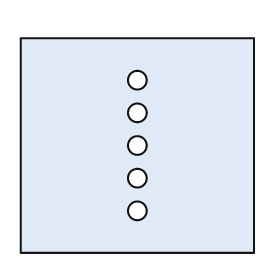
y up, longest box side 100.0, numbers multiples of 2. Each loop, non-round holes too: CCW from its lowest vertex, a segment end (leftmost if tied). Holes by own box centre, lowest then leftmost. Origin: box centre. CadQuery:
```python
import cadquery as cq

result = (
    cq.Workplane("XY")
    .moveTo(-50.0, -46.0)
    .lineTo(50.0, -46.0)
    .lineTo(50.0, 46.0)
    .lineTo(-50.0, 46.0)
    .close()
    .moveTo(0.0, -28.0)
    .circle(4.0)
    .moveTo(0.0, -14.0)
    .circle(4.0)
    .moveTo(0.0, 0.0)
    .circle(4.0)
    .moveTo(0.0, 14.0)
    .circle(4.0)
    .moveTo(0.0, 28.0)
    .circle(4.0)
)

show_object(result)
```